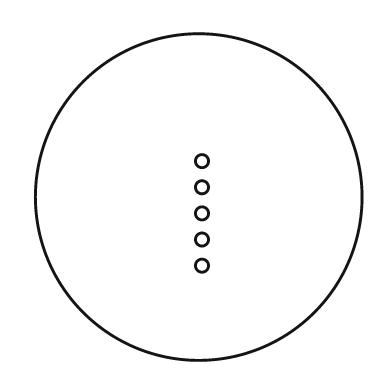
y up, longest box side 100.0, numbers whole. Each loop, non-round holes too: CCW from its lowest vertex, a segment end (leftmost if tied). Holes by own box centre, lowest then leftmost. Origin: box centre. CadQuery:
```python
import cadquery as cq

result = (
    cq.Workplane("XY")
    .moveTo(0.0, 0.0)
    .circle(50.0)
    .moveTo(1.0, -21.0)
    .circle(2.0)
    .moveTo(1.0, -13.0)
    .circle(2.0)
    .moveTo(1.0, -5.0)
    .circle(2.0)
    .moveTo(1.0, 3.0)
    .circle(2.0)
    .moveTo(1.0, 11.0)
    .circle(2.0)
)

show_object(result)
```